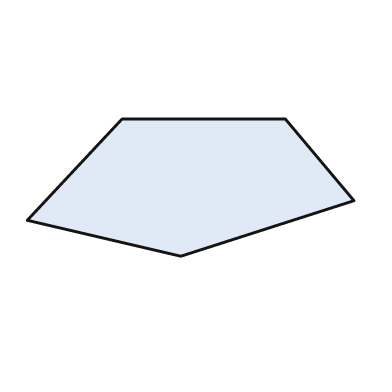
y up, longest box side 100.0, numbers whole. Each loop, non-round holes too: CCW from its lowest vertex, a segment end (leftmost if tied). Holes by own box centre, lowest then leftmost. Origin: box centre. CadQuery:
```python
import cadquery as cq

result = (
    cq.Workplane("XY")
    .moveTo(-3.0, -21.0)
    .lineTo(50.0, -4.0)
    .lineTo(29.0, 21.0)
    .lineTo(-21.0, 21.0)
    .lineTo(-50.0, -10.0)
    .close()
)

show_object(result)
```